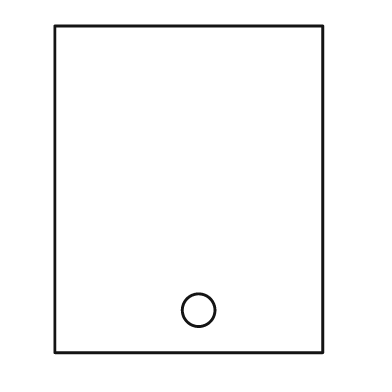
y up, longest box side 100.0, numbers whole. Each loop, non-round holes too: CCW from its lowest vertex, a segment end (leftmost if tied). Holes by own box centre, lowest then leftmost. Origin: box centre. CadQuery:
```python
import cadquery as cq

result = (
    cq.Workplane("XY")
    .moveTo(-41.0, -50.0)
    .lineTo(41.0, -50.0)
    .lineTo(41.0, 50.0)
    .lineTo(-41.0, 50.0)
    .close()
    .moveTo(3.0, -37.0)
    .circle(5.0)
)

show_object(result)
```